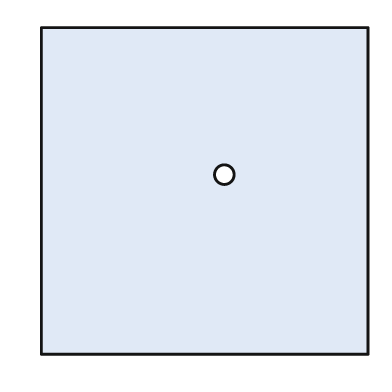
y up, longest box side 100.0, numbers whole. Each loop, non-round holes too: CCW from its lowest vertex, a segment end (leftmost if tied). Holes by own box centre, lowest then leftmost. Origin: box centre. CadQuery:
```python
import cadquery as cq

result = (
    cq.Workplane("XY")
    .moveTo(-50.0, -50.0)
    .lineTo(50.0, -50.0)
    .lineTo(50.0, 50.0)
    .lineTo(-50.0, 50.0)
    .close()
    .moveTo(6.0, 5.0)
    .circle(3.0)
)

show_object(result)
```